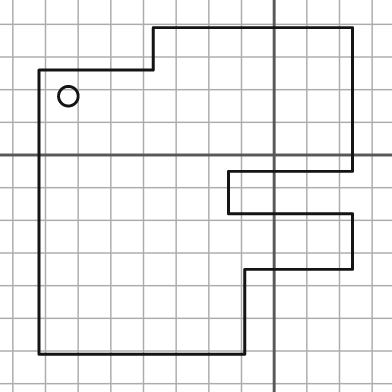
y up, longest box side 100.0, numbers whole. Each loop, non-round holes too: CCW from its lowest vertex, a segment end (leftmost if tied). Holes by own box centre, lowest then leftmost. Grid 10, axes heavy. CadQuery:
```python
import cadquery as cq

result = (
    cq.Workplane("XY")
    .moveTo(-72.0, -61.0)
    .lineTo(-9.0, -61.0)
    .lineTo(-9.0, -35.0)
    .lineTo(24.0, -35.0)
    .lineTo(24.0, -18.0)
    .lineTo(-14.0, -18.0)
    .lineTo(-14.0, -5.0)
    .lineTo(24.0, -5.0)
    .lineTo(24.0, 39.0)
    .lineTo(-37.0, 39.0)
    .lineTo(-37.0, 26.0)
    .lineTo(-72.0, 26.0)
    .close()
    .moveTo(-63.0, 18.0)
    .circle(3.0)
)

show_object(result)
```